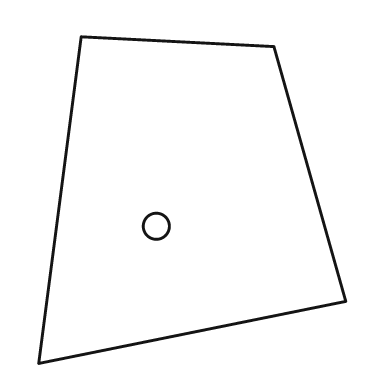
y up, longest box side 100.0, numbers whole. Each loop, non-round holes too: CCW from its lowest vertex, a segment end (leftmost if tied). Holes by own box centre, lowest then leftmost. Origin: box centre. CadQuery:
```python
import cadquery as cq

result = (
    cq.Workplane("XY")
    .moveTo(-47.0, -50.0)
    .lineTo(47.0, -31.0)
    .lineTo(25.0, 47.0)
    .lineTo(-34.0, 50.0)
    .close()
    .moveTo(-11.0, -8.0)
    .circle(4.0)
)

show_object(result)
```